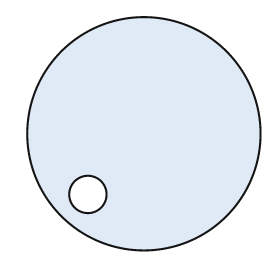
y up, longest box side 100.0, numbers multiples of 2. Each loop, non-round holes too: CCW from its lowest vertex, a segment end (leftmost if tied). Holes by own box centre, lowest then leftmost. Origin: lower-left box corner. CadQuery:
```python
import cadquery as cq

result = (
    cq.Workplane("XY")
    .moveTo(50.0, 50.0)
    .circle(50.0)
    .moveTo(26.0, 24.0)
    .circle(8.0)
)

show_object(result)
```